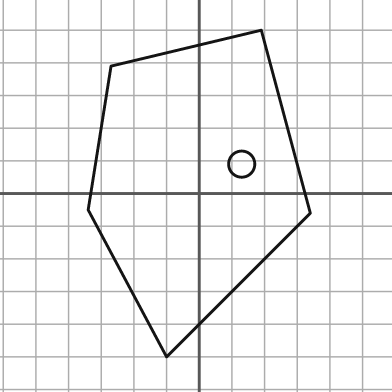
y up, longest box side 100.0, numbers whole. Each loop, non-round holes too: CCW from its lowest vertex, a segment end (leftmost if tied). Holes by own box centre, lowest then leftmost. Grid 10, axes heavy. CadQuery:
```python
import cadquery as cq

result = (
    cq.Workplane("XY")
    .moveTo(-10.0, -50.0)
    .lineTo(34.0, -6.0)
    .lineTo(19.0, 50.0)
    .lineTo(-27.0, 39.0)
    .lineTo(-34.0, -5.0)
    .close()
    .moveTo(13.0, 9.0)
    .circle(4.0)
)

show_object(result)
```